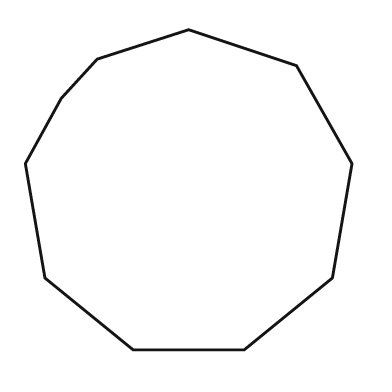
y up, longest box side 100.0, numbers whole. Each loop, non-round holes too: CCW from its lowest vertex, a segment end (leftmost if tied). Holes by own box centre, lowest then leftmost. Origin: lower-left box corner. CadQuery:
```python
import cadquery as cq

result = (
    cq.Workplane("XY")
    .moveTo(33.0, 0.0)
    .lineTo(67.0, 0.0)
    .lineTo(94.0, 22.0)
    .lineTo(100.0, 57.0)
    .lineTo(83.0, 87.0)
    .lineTo(50.0, 98.0)
    .lineTo(22.0, 89.0)
    .lineTo(11.0, 77.0)
    .lineTo(0.0, 57.0)
    .lineTo(6.0, 22.0)
    .close()
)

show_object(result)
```